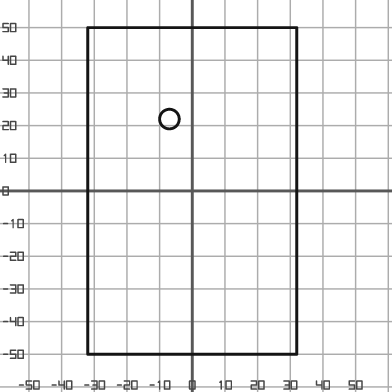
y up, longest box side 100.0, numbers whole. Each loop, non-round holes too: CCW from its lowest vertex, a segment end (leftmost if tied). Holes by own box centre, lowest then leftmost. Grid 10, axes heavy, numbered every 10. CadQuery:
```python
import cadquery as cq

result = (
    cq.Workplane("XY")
    .moveTo(-32.0, -50.0)
    .lineTo(32.0, -50.0)
    .lineTo(32.0, 50.0)
    .lineTo(-32.0, 50.0)
    .close()
    .moveTo(-7.0, 22.0)
    .circle(3.0)
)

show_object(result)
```